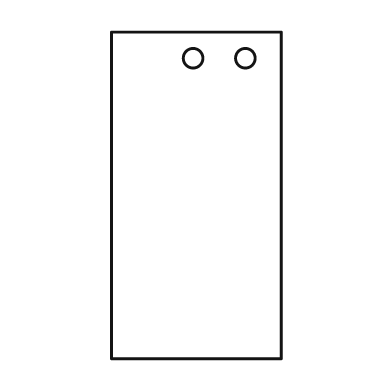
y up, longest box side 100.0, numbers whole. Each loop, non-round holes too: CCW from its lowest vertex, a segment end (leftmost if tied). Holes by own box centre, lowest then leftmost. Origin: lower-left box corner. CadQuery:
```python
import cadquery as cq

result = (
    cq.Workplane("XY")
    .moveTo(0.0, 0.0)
    .lineTo(52.0, 0.0)
    .lineTo(52.0, 100.0)
    .lineTo(0.0, 100.0)
    .close()
    .moveTo(25.0, 92.0)
    .circle(3.0)
    .moveTo(41.0, 92.0)
    .circle(3.0)
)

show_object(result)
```